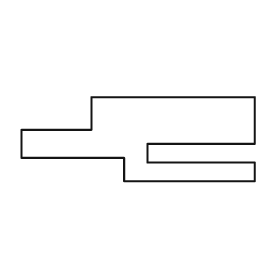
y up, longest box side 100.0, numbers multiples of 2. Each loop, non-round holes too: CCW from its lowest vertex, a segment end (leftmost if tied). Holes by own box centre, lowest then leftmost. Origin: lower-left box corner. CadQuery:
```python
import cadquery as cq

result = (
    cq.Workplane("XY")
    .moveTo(44.0, 0.0)
    .lineTo(100.0, 0.0)
    .lineTo(100.0, 8.0)
    .lineTo(54.0, 8.0)
    .lineTo(54.0, 16.0)
    .lineTo(100.0, 16.0)
    .lineTo(100.0, 36.0)
    .lineTo(30.0, 36.0)
    .lineTo(30.0, 22.0)
    .lineTo(0.0, 22.0)
    .lineTo(0.0, 10.0)
    .lineTo(44.0, 10.0)
    .close()
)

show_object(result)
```